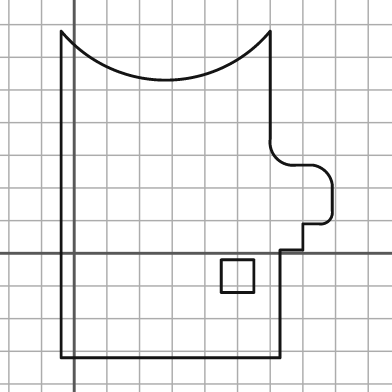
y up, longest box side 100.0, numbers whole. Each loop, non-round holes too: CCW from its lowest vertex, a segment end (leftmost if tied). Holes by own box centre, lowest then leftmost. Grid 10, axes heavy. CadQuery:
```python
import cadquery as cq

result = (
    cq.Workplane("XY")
    .moveTo(-4.0, -32.0)
    .lineTo(63.0, -32.0)
    .lineTo(63.0, 1.0)
    .lineTo(70.0, 1.0)
    .lineTo(70.0, 9.0)
    .lineTo(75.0, 9.0)
    .threePointArc((78.0, 10.0), (79.0, 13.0))
    .lineTo(79.0, 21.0)
    .threePointArc((77.0, 25.0), (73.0, 27.0))
    .lineTo(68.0, 27.0)
    .threePointArc((62.0, 29.0), (60.0, 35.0))
    .lineTo(60.0, 68.0)
    .threePointArc((28.0, 53.0), (-4.0, 68.0))
    .close()
    .moveTo(45.0, -12.0)
    .lineTo(55.0, -12.0)
    .lineTo(55.0, -2.0)
    .lineTo(45.0, -2.0)
    .close()
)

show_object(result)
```